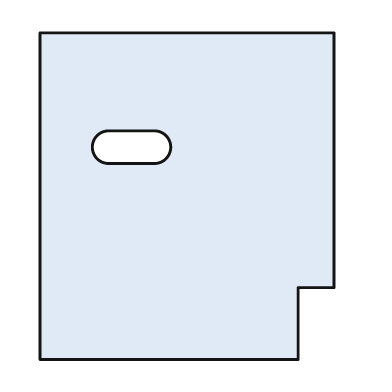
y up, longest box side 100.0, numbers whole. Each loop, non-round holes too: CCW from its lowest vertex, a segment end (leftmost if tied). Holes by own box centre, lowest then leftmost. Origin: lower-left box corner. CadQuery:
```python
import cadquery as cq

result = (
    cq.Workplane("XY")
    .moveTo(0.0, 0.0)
    .lineTo(79.0, 0.0)
    .lineTo(79.0, 22.0)
    .lineTo(90.0, 22.0)
    .lineTo(90.0, 100.0)
    .lineTo(0.0, 100.0)
    .close()
    .moveTo(21.0, 60.0)
    .lineTo(35.0, 60.0)
    .threePointArc((40.0, 65.0), (35.0, 70.0))
    .lineTo(21.0, 70.0)
    .threePointArc((16.0, 65.0), (21.0, 60.0))
    .close()
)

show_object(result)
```